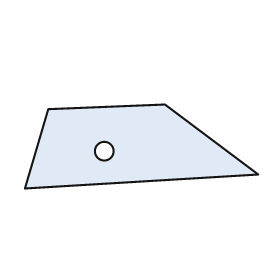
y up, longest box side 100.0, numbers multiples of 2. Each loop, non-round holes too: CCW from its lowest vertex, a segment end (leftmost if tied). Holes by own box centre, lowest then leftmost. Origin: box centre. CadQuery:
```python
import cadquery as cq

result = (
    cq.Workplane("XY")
    .moveTo(-50.0, -18.0)
    .lineTo(50.0, -12.0)
    .lineTo(10.0, 18.0)
    .lineTo(-40.0, 16.0)
    .close()
    .moveTo(-16.0, -2.0)
    .circle(4.0)
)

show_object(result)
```